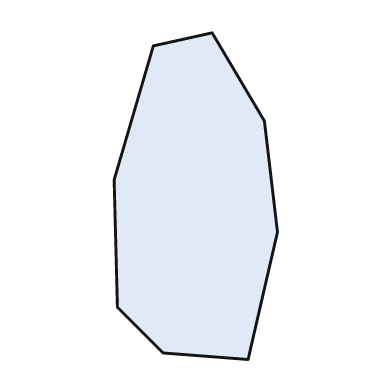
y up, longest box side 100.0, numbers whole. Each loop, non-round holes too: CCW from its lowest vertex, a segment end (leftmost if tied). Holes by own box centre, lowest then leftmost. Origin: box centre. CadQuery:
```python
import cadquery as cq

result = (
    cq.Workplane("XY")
    .moveTo(16.0, -50.0)
    .lineTo(25.0, -11.0)
    .lineTo(21.0, 23.0)
    .lineTo(5.0, 50.0)
    .lineTo(-13.0, 46.0)
    .lineTo(-25.0, 5.0)
    .lineTo(-24.0, -34.0)
    .lineTo(-10.0, -48.0)
    .close()
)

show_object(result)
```